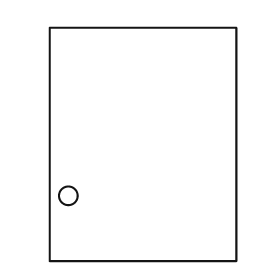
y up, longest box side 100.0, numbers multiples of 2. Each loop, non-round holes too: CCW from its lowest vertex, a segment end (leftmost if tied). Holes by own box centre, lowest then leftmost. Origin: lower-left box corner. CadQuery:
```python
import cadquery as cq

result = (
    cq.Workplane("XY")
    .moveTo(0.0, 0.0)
    .lineTo(80.0, 0.0)
    .lineTo(80.0, 100.0)
    .lineTo(0.0, 100.0)
    .close()
    .moveTo(8.0, 28.0)
    .circle(4.0)
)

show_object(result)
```